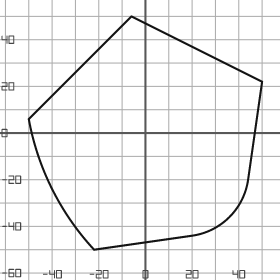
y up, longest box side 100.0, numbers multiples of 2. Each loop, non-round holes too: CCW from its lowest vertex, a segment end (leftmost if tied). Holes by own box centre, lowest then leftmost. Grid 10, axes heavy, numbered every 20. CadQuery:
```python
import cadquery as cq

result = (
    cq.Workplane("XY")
    .moveTo(-22.0, -50.0)
    .lineTo(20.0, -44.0)
    .threePointArc((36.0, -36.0), (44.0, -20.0))
    .lineTo(50.0, 22.0)
    .lineTo(-6.0, 50.0)
    .lineTo(-50.0, 6.0)
    .threePointArc((-40.0, -24.0), (-22.0, -50.0))
    .close()
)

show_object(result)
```